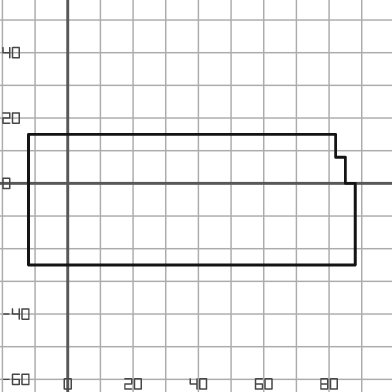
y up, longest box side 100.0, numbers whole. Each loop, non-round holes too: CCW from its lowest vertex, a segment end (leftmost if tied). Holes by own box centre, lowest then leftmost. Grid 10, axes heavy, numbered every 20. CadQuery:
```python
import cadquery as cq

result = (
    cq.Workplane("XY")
    .moveTo(-12.0, -25.0)
    .lineTo(88.0, -25.0)
    .lineTo(88.0, 0.0)
    .lineTo(85.0, 0.0)
    .lineTo(85.0, 8.0)
    .lineTo(82.0, 8.0)
    .lineTo(82.0, 15.0)
    .lineTo(-12.0, 15.0)
    .close()
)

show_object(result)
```